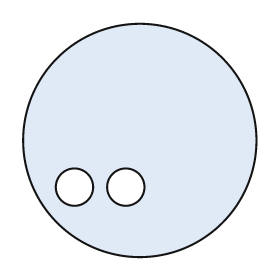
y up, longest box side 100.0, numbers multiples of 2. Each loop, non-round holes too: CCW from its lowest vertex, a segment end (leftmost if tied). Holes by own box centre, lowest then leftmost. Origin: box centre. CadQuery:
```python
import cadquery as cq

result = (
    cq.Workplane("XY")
    .moveTo(0.0, 0.0)
    .circle(50.0)
    .moveTo(-28.0, -20.0)
    .circle(8.0)
    .moveTo(-6.0, -20.0)
    .circle(8.0)
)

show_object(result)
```